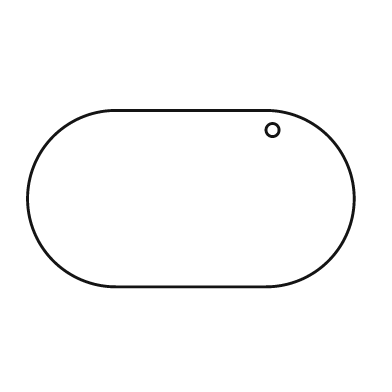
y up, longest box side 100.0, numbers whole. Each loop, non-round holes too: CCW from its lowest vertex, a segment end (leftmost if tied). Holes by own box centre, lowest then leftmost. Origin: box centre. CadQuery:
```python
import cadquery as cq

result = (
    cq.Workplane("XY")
    .moveTo(-23.0, -27.0)
    .lineTo(23.0, -27.0)
    .threePointArc((50.0, 0.0), (23.0, 27.0))
    .lineTo(-23.0, 27.0)
    .threePointArc((-50.0, 0.0), (-23.0, -27.0))
    .close()
    .moveTo(25.0, 21.0)
    .circle(2.0)
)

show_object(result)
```